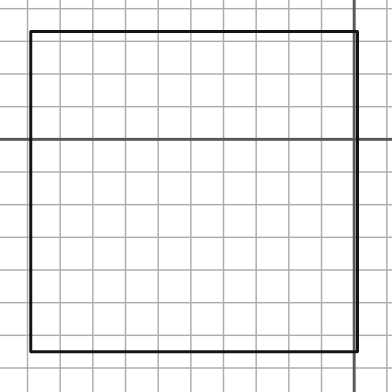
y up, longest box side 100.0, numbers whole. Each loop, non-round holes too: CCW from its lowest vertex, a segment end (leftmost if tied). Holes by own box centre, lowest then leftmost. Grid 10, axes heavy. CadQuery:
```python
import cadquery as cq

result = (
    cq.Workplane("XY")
    .moveTo(-99.0, -65.0)
    .lineTo(1.0, -65.0)
    .lineTo(1.0, 33.0)
    .lineTo(-99.0, 33.0)
    .close()
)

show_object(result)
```